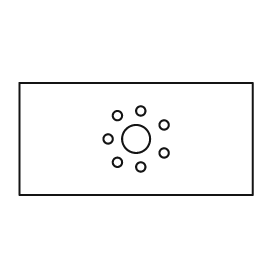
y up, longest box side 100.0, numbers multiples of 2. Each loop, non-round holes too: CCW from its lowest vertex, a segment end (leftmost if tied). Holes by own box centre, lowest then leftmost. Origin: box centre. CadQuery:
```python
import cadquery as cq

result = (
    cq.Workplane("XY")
    .moveTo(-50.0, -24.0)
    .lineTo(50.0, -24.0)
    .lineTo(50.0, 24.0)
    .lineTo(-50.0, 24.0)
    .close()
    .moveTo(2.0, -12.0)
    .circle(2.0)
    .moveTo(-8.0, -10.0)
    .circle(2.0)
    .moveTo(12.0, -6.0)
    .circle(2.0)
    .moveTo(-12.0, 0.0)
    .circle(2.0)
    .moveTo(0.0, 0.0)
    .circle(6.0)
    .moveTo(12.0, 6.0)
    .circle(2.0)
    .moveTo(-8.0, 10.0)
    .circle(2.0)
    .moveTo(2.0, 12.0)
    .circle(2.0)
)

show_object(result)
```